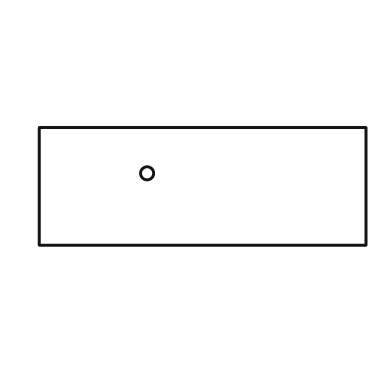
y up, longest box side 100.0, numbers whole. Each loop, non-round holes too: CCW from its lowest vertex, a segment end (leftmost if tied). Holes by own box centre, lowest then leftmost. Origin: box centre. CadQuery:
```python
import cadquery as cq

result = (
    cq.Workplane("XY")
    .moveTo(-50.0, -18.0)
    .lineTo(50.0, -18.0)
    .lineTo(50.0, 18.0)
    .lineTo(-50.0, 18.0)
    .close()
    .moveTo(-17.0, 4.0)
    .circle(2.0)
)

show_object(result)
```